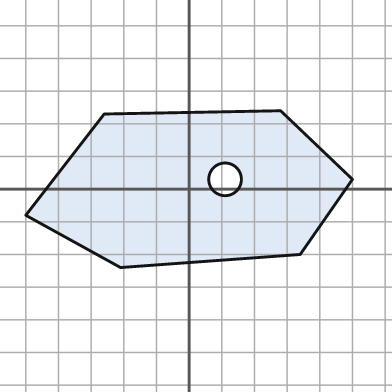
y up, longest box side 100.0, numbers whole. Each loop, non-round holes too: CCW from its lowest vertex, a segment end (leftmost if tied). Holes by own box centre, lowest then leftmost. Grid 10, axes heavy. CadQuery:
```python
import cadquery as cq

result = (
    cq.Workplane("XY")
    .moveTo(-21.0, -24.0)
    .lineTo(34.0, -20.0)
    .lineTo(50.0, 3.0)
    .lineTo(28.0, 24.0)
    .lineTo(-26.0, 23.0)
    .lineTo(-50.0, -8.0)
    .close()
    .moveTo(11.0, 3.0)
    .circle(5.0)
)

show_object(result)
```